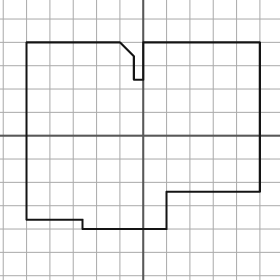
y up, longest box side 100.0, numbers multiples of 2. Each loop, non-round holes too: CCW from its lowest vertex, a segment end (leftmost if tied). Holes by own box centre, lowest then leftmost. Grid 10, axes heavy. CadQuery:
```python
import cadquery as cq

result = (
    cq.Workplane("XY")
    .moveTo(-26.0, -40.0)
    .lineTo(10.0, -40.0)
    .lineTo(10.0, -24.0)
    .lineTo(50.0, -24.0)
    .lineTo(50.0, 40.0)
    .lineTo(0.0, 40.0)
    .lineTo(0.0, 24.0)
    .lineTo(-4.0, 24.0)
    .lineTo(-4.0, 34.0)
    .lineTo(-10.0, 40.0)
    .lineTo(-50.0, 40.0)
    .lineTo(-50.0, -36.0)
    .lineTo(-26.0, -36.0)
    .close()
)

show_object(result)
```